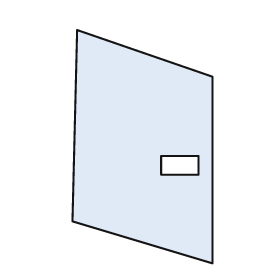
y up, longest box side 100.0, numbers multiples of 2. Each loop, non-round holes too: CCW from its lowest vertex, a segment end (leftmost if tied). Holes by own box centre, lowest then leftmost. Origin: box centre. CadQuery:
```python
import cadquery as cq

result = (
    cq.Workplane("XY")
    .moveTo(30.0, -50.0)
    .lineTo(30.0, 30.0)
    .lineTo(-28.0, 50.0)
    .lineTo(-30.0, -32.0)
    .close()
    .moveTo(8.0, -12.0)
    .lineTo(24.0, -12.0)
    .lineTo(24.0, -4.0)
    .lineTo(8.0, -4.0)
    .close()
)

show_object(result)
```